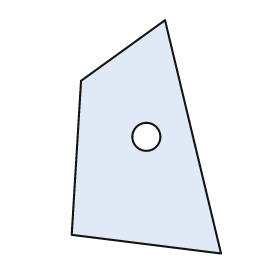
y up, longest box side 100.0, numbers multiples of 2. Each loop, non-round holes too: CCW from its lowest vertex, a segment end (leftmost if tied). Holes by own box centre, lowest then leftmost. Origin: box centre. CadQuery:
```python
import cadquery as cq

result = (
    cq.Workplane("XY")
    .moveTo(32.0, -50.0)
    .lineTo(8.0, 50.0)
    .lineTo(-28.0, 24.0)
    .lineTo(-32.0, -42.0)
    .close()
    .moveTo(0.0, 0.0)
    .circle(6.0)
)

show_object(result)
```